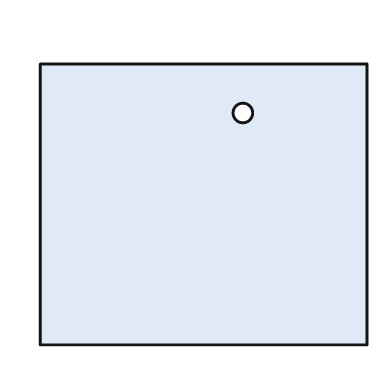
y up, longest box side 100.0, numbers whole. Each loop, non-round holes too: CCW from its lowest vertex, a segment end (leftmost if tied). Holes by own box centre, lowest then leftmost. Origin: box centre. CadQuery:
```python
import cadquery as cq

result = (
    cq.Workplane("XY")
    .moveTo(-50.0, -43.0)
    .lineTo(50.0, -43.0)
    .lineTo(50.0, 43.0)
    .lineTo(-50.0, 43.0)
    .close()
    .moveTo(12.0, 28.0)
    .circle(3.0)
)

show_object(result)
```